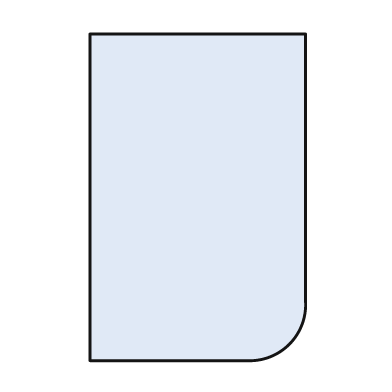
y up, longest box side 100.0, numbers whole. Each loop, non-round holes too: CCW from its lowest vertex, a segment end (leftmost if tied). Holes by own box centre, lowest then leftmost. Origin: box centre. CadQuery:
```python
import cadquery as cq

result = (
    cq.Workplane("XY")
    .moveTo(-33.0, -50.0)
    .lineTo(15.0, -50.0)
    .threePointArc((28.0, -45.0), (33.0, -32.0))
    .lineTo(33.0, 50.0)
    .lineTo(-33.0, 50.0)
    .close()
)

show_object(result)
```